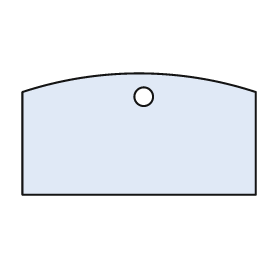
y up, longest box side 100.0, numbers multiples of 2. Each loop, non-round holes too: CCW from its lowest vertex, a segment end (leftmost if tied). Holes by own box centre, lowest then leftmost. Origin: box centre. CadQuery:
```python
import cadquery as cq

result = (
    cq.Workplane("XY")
    .moveTo(-50.0, -26.0)
    .lineTo(50.0, -26.0)
    .lineTo(50.0, 18.0)
    .threePointArc((0.0, 26.0), (-50.0, 18.0))
    .close()
    .moveTo(2.0, 16.0)
    .circle(4.0)
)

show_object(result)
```